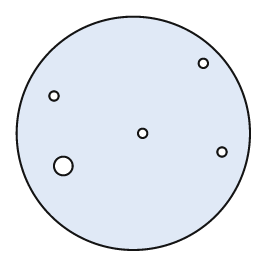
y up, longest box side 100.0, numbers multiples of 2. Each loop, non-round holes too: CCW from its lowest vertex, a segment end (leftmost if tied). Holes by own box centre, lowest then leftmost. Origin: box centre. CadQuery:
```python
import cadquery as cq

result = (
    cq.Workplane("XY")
    .moveTo(0.0, 0.0)
    .circle(50.0)
    .moveTo(-30.0, -14.0)
    .circle(4.0)
    .moveTo(38.0, -8.0)
    .circle(2.0)
    .moveTo(4.0, 0.0)
    .circle(2.0)
    .moveTo(-34.0, 16.0)
    .circle(2.0)
    .moveTo(30.0, 30.0)
    .circle(2.0)
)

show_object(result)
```